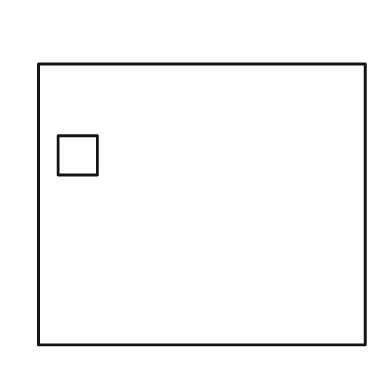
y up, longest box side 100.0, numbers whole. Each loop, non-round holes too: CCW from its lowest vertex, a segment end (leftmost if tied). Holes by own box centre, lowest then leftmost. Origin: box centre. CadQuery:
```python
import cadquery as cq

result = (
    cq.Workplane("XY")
    .moveTo(-50.0, -43.0)
    .lineTo(50.0, -43.0)
    .lineTo(50.0, 43.0)
    .lineTo(-50.0, 43.0)
    .close()
    .moveTo(-44.0, 9.0)
    .lineTo(-32.0, 9.0)
    .lineTo(-32.0, 21.0)
    .lineTo(-44.0, 21.0)
    .close()
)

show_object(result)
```